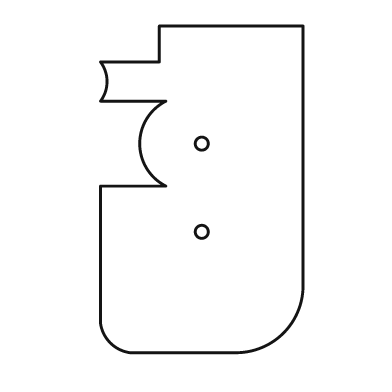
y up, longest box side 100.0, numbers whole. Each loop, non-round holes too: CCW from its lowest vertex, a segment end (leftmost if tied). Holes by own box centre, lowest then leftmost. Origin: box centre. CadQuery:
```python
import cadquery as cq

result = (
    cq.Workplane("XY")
    .moveTo(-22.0, -50.0)
    .lineTo(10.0, -50.0)
    .threePointArc((25.0, -44.0), (31.0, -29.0))
    .lineTo(31.0, 50.0)
    .lineTo(-13.0, 50.0)
    .lineTo(-13.0, 39.0)
    .lineTo(-31.0, 39.0)
    .threePointArc((-29.0, 33.0), (-31.0, 27.0))
    .lineTo(-11.0, 27.0)
    .threePointArc((-19.0, 14.0), (-11.0, 1.0))
    .lineTo(-31.0, 1.0)
    .lineTo(-31.0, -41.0)
    .threePointArc((-28.0, -47.0), (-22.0, -50.0))
    .close()
    .moveTo(0.0, -13.0)
    .circle(2.0)
    .moveTo(0.0, 14.0)
    .circle(2.0)
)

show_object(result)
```